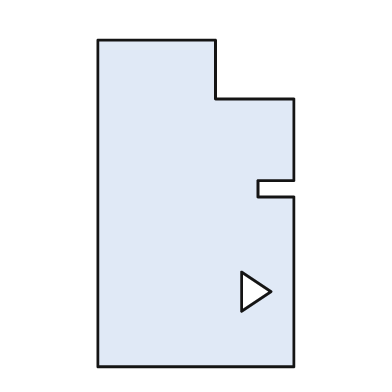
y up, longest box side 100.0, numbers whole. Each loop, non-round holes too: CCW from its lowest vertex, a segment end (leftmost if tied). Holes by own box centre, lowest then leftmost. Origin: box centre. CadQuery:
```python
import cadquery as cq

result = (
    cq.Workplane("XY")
    .moveTo(-30.0, -50.0)
    .lineTo(30.0, -50.0)
    .lineTo(30.0, 2.0)
    .lineTo(19.0, 2.0)
    .lineTo(19.0, 7.0)
    .lineTo(30.0, 7.0)
    .lineTo(30.0, 32.0)
    .lineTo(6.0, 32.0)
    .lineTo(6.0, 50.0)
    .lineTo(-30.0, 50.0)
    .close()
    .moveTo(14.0, -33.0)
    .lineTo(23.0, -27.0)
    .lineTo(14.0, -21.0)
    .close()
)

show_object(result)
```